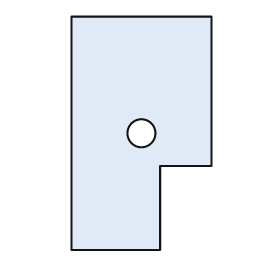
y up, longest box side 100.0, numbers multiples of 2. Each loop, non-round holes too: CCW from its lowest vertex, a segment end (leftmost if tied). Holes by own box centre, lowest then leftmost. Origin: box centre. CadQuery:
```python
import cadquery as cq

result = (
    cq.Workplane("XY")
    .moveTo(-30.0, -50.0)
    .lineTo(8.0, -50.0)
    .lineTo(8.0, -14.0)
    .lineTo(30.0, -14.0)
    .lineTo(30.0, 50.0)
    .lineTo(-30.0, 50.0)
    .close()
    .moveTo(0.0, 0.0)
    .circle(6.0)
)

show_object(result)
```